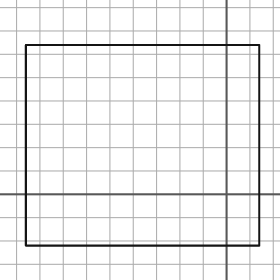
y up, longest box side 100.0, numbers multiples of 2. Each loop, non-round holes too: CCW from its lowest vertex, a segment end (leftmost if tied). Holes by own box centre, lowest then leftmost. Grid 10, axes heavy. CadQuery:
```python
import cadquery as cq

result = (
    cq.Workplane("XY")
    .moveTo(-86.0, -22.0)
    .lineTo(14.0, -22.0)
    .lineTo(14.0, 64.0)
    .lineTo(-86.0, 64.0)
    .close()
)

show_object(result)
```